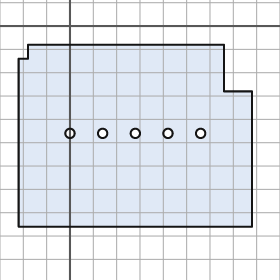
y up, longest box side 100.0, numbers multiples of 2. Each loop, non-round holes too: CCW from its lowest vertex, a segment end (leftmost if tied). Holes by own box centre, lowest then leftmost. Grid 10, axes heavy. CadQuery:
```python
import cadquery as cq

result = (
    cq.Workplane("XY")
    .moveTo(-22.0, -86.0)
    .lineTo(78.0, -86.0)
    .lineTo(78.0, -28.0)
    .lineTo(66.0, -28.0)
    .lineTo(66.0, -8.0)
    .lineTo(-18.0, -8.0)
    .lineTo(-18.0, -14.0)
    .lineTo(-22.0, -14.0)
    .close()
    .moveTo(0.0, -46.0)
    .circle(2.0)
    .moveTo(14.0, -46.0)
    .circle(2.0)
    .moveTo(28.0, -46.0)
    .circle(2.0)
    .moveTo(42.0, -46.0)
    .circle(2.0)
    .moveTo(56.0, -46.0)
    .circle(2.0)
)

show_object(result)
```